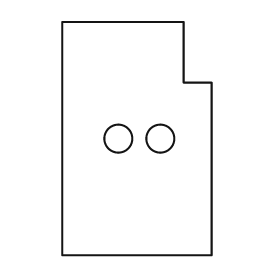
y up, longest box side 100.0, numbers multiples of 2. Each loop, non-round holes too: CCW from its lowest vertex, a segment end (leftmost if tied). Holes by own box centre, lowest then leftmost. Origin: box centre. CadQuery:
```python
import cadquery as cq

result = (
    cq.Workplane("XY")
    .moveTo(-32.0, -50.0)
    .lineTo(32.0, -50.0)
    .lineTo(32.0, 24.0)
    .lineTo(20.0, 24.0)
    .lineTo(20.0, 50.0)
    .lineTo(-32.0, 50.0)
    .close()
    .moveTo(-8.0, 0.0)
    .circle(6.0)
    .moveTo(10.0, 0.0)
    .circle(6.0)
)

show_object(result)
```